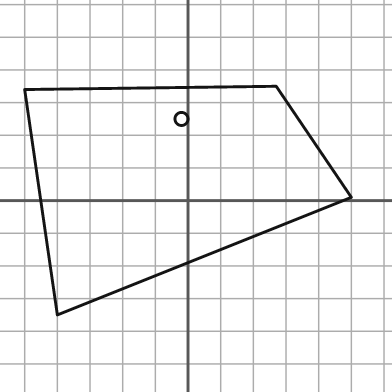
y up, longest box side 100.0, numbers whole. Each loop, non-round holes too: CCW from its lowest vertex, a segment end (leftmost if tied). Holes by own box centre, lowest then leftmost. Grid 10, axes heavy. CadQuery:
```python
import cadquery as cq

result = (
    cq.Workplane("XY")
    .moveTo(-40.0, -35.0)
    .lineTo(50.0, 1.0)
    .lineTo(27.0, 35.0)
    .lineTo(-50.0, 34.0)
    .close()
    .moveTo(-2.0, 25.0)
    .circle(2.0)
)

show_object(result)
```